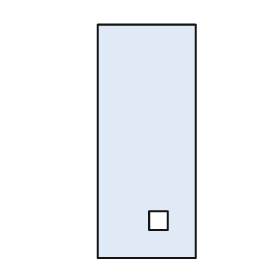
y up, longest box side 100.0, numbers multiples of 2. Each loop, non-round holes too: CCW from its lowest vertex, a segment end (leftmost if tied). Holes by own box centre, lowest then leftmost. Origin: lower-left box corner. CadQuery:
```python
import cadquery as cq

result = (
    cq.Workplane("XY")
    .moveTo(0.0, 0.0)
    .lineTo(42.0, 0.0)
    .lineTo(42.0, 100.0)
    .lineTo(0.0, 100.0)
    .close()
    .moveTo(22.0, 12.0)
    .lineTo(30.0, 12.0)
    .lineTo(30.0, 20.0)
    .lineTo(22.0, 20.0)
    .close()
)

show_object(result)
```